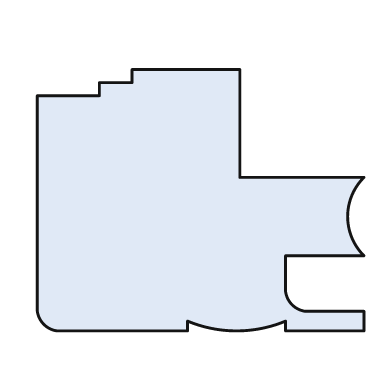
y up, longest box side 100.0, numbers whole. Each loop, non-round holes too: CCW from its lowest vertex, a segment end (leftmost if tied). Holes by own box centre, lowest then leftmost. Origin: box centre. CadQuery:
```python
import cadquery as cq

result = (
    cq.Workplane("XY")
    .moveTo(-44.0, -40.0)
    .lineTo(-4.0, -40.0)
    .lineTo(-4.0, -37.0)
    .threePointArc((11.0, -40.0), (26.0, -37.0))
    .lineTo(26.0, -40.0)
    .lineTo(50.0, -40.0)
    .lineTo(50.0, -34.0)
    .lineTo(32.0, -34.0)
    .threePointArc((28.0, -32.0), (26.0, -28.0))
    .lineTo(26.0, -17.0)
    .lineTo(50.0, -17.0)
    .threePointArc((45.0, -5.0), (50.0, 7.0))
    .lineTo(12.0, 7.0)
    .lineTo(12.0, 40.0)
    .lineTo(-21.0, 40.0)
    .lineTo(-21.0, 36.0)
    .lineTo(-31.0, 36.0)
    .lineTo(-31.0, 32.0)
    .lineTo(-50.0, 32.0)
    .lineTo(-50.0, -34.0)
    .threePointArc((-48.0, -38.0), (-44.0, -40.0))
    .close()
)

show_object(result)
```